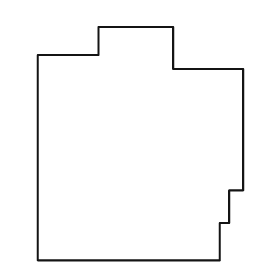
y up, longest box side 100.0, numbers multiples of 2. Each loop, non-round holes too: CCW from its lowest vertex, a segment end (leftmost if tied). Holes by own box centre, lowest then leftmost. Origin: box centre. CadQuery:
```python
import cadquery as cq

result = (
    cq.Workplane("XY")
    .moveTo(-44.0, -50.0)
    .lineTo(34.0, -50.0)
    .lineTo(34.0, -34.0)
    .lineTo(38.0, -34.0)
    .lineTo(38.0, -20.0)
    .lineTo(44.0, -20.0)
    .lineTo(44.0, 32.0)
    .lineTo(14.0, 32.0)
    .lineTo(14.0, 50.0)
    .lineTo(-18.0, 50.0)
    .lineTo(-18.0, 38.0)
    .lineTo(-44.0, 38.0)
    .close()
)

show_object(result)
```